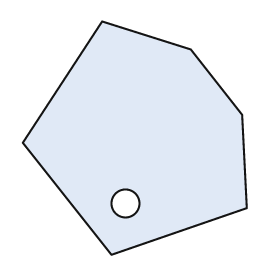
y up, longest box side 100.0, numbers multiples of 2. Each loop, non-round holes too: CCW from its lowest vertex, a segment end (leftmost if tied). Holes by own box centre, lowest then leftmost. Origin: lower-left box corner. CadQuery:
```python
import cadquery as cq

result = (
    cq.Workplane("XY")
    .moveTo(38.0, 0.0)
    .lineTo(96.0, 20.0)
    .lineTo(94.0, 60.0)
    .lineTo(72.0, 88.0)
    .lineTo(34.0, 100.0)
    .lineTo(0.0, 48.0)
    .close()
    .moveTo(44.0, 22.0)
    .circle(6.0)
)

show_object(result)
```